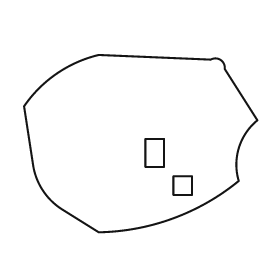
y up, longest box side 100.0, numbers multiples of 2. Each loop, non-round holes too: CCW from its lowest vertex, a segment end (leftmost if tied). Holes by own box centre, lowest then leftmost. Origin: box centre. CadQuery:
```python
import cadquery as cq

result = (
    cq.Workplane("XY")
    .moveTo(-18.0, -38.0)
    .threePointArc((14.0, -32.0), (42.0, -16.0))
    .threePointArc((42.0, -2.0), (50.0, 10.0))
    .lineTo(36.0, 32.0)
    .threePointArc((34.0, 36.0), (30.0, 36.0))
    .lineTo(-18.0, 38.0)
    .threePointArc((-36.0, 30.0), (-50.0, 16.0))
    .lineTo(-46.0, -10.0)
    .threePointArc((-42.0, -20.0), (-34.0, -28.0))
    .close()
    .moveTo(14.0, -22.0)
    .lineTo(22.0, -22.0)
    .lineTo(22.0, -14.0)
    .lineTo(14.0, -14.0)
    .close()
    .moveTo(2.0, -10.0)
    .lineTo(10.0, -10.0)
    .lineTo(10.0, 2.0)
    .lineTo(2.0, 2.0)
    .close()
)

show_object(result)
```